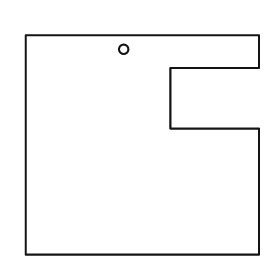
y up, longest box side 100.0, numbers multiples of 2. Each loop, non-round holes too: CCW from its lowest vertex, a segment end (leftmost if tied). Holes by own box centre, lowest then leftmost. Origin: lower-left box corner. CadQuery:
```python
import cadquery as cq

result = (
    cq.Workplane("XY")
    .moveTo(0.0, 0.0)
    .lineTo(100.0, 0.0)
    .lineTo(100.0, 54.0)
    .lineTo(62.0, 54.0)
    .lineTo(62.0, 80.0)
    .lineTo(100.0, 80.0)
    .lineTo(100.0, 94.0)
    .lineTo(0.0, 94.0)
    .close()
    .moveTo(42.0, 88.0)
    .circle(2.0)
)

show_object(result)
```